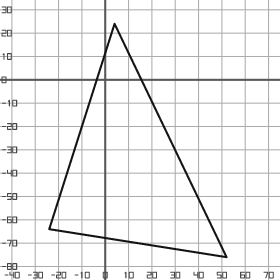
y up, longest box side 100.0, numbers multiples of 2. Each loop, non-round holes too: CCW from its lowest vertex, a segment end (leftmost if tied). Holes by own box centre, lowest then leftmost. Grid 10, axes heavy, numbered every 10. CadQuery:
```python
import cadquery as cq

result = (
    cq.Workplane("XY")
    .moveTo(52.0, -76.0)
    .lineTo(4.0, 24.0)
    .lineTo(-24.0, -64.0)
    .close()
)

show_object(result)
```